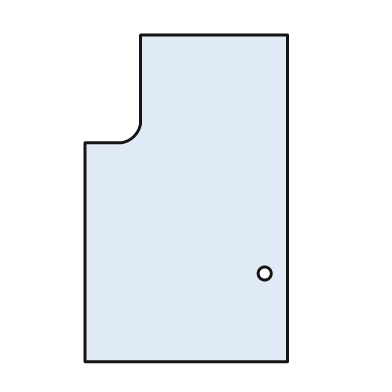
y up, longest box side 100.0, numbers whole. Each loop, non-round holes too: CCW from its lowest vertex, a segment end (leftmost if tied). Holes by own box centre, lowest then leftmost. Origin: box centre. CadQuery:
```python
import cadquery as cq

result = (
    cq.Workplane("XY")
    .moveTo(-31.0, -50.0)
    .lineTo(31.0, -50.0)
    .lineTo(31.0, 50.0)
    .lineTo(-14.0, 50.0)
    .lineTo(-14.0, 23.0)
    .threePointArc((-16.0, 19.0), (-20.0, 17.0))
    .lineTo(-31.0, 17.0)
    .close()
    .moveTo(24.0, -23.0)
    .circle(2.0)
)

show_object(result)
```